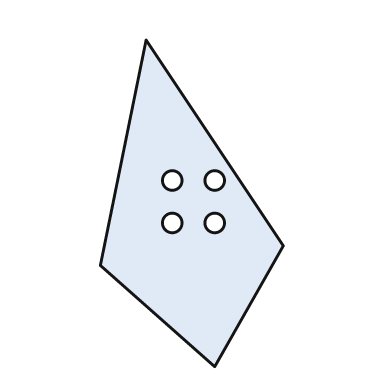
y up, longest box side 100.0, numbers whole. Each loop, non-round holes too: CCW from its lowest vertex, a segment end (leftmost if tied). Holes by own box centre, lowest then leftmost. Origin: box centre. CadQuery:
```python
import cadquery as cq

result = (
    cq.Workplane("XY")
    .moveTo(7.0, -50.0)
    .lineTo(28.0, -13.0)
    .lineTo(-14.0, 50.0)
    .lineTo(-28.0, -19.0)
    .close()
    .moveTo(-6.0, -6.0)
    .circle(3.0)
    .moveTo(7.0, -6.0)
    .circle(3.0)
    .moveTo(-6.0, 7.0)
    .circle(3.0)
    .moveTo(7.0, 7.0)
    .circle(3.0)
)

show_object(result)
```